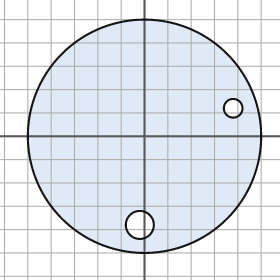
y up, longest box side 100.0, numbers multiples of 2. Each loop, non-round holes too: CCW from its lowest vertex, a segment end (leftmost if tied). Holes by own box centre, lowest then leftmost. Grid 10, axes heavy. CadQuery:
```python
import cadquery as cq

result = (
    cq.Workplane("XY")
    .moveTo(0.0, 0.0)
    .circle(50.0)
    .moveTo(-2.0, -38.0)
    .circle(6.0)
    .moveTo(38.0, 12.0)
    .circle(4.0)
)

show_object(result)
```